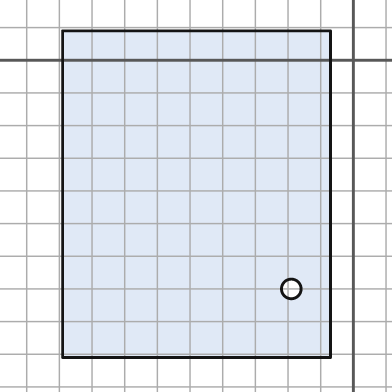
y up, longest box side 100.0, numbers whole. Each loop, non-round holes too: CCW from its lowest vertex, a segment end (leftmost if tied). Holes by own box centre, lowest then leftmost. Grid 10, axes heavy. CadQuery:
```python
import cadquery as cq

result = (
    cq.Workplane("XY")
    .moveTo(-89.0, -91.0)
    .lineTo(-7.0, -91.0)
    .lineTo(-7.0, 9.0)
    .lineTo(-89.0, 9.0)
    .close()
    .moveTo(-19.0, -70.0)
    .circle(3.0)
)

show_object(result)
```